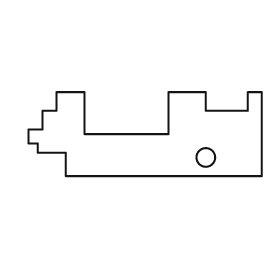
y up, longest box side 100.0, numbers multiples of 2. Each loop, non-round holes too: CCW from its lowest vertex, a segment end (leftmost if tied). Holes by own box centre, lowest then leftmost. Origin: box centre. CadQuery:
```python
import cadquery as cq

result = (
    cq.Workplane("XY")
    .moveTo(-34.0, -18.0)
    .lineTo(50.0, -18.0)
    .lineTo(50.0, 18.0)
    .lineTo(44.0, 18.0)
    .lineTo(44.0, 10.0)
    .lineTo(26.0, 10.0)
    .lineTo(26.0, 18.0)
    .lineTo(10.0, 18.0)
    .lineTo(10.0, 0.0)
    .lineTo(-26.0, 0.0)
    .lineTo(-26.0, 18.0)
    .lineTo(-38.0, 18.0)
    .lineTo(-38.0, 10.0)
    .lineTo(-44.0, 10.0)
    .lineTo(-44.0, 2.0)
    .lineTo(-50.0, 2.0)
    .lineTo(-50.0, -4.0)
    .lineTo(-46.0, -4.0)
    .lineTo(-46.0, -8.0)
    .lineTo(-34.0, -8.0)
    .close()
    .moveTo(26.0, -10.0)
    .circle(4.0)
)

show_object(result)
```